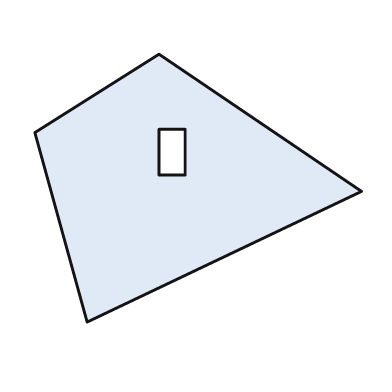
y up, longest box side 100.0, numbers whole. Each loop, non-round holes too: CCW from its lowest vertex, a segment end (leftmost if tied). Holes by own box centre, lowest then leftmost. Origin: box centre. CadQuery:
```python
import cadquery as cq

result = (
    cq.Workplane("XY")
    .moveTo(-34.0, -41.0)
    .lineTo(50.0, -1.0)
    .lineTo(-12.0, 41.0)
    .lineTo(-50.0, 17.0)
    .close()
    .moveTo(-12.0, 4.0)
    .lineTo(-4.0, 4.0)
    .lineTo(-4.0, 18.0)
    .lineTo(-12.0, 18.0)
    .close()
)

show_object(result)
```